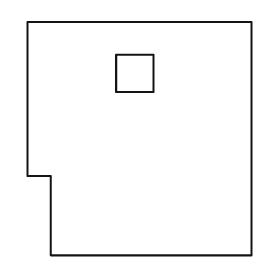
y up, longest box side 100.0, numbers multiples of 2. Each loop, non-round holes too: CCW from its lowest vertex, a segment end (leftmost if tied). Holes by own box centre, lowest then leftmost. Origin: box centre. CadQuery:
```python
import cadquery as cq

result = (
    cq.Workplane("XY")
    .moveTo(-38.0, -50.0)
    .lineTo(48.0, -50.0)
    .lineTo(48.0, 50.0)
    .lineTo(-48.0, 50.0)
    .lineTo(-48.0, -16.0)
    .lineTo(-38.0, -16.0)
    .close()
    .moveTo(-10.0, 20.0)
    .lineTo(6.0, 20.0)
    .lineTo(6.0, 36.0)
    .lineTo(-10.0, 36.0)
    .close()
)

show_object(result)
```